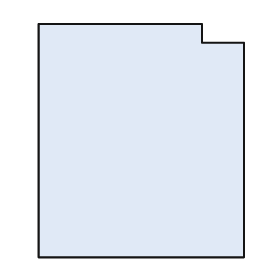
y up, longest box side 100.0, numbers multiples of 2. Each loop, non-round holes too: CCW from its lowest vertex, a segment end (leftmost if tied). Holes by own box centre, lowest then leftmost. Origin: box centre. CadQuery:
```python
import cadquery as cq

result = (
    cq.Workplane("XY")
    .moveTo(-44.0, -50.0)
    .lineTo(44.0, -50.0)
    .lineTo(44.0, 42.0)
    .lineTo(26.0, 42.0)
    .lineTo(26.0, 50.0)
    .lineTo(-44.0, 50.0)
    .close()
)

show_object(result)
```